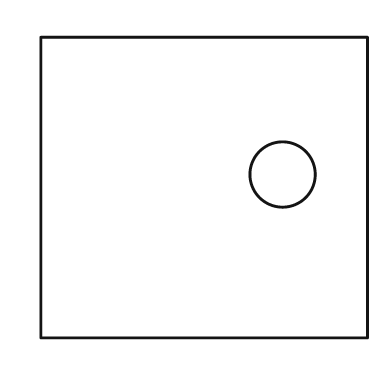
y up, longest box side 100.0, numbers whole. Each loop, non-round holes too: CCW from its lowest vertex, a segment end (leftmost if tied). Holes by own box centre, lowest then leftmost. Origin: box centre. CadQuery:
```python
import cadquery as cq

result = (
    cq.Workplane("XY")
    .moveTo(-50.0, -46.0)
    .lineTo(50.0, -46.0)
    .lineTo(50.0, 46.0)
    .lineTo(-50.0, 46.0)
    .close()
    .moveTo(24.0, 4.0)
    .circle(10.0)
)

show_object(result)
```